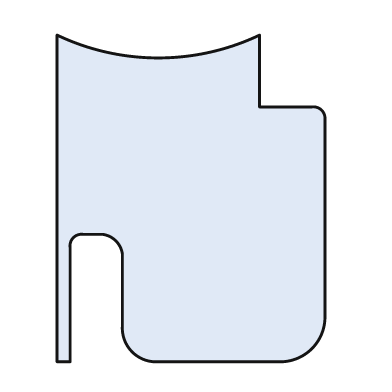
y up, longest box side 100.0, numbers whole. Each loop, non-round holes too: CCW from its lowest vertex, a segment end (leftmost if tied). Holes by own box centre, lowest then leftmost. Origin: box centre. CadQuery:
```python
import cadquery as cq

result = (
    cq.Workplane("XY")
    .moveTo(-41.0, -50.0)
    .lineTo(-37.0, -50.0)
    .lineTo(-37.0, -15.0)
    .threePointArc((-36.0, -12.0), (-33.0, -11.0))
    .lineTo(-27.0, -11.0)
    .threePointArc((-23.0, -13.0), (-21.0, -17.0))
    .lineTo(-21.0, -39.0)
    .threePointArc((-18.0, -47.0), (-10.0, -50.0))
    .lineTo(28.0, -50.0)
    .threePointArc((37.0, -46.0), (41.0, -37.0))
    .lineTo(41.0, 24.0)
    .threePointArc((40.0, 27.0), (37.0, 28.0))
    .lineTo(21.0, 28.0)
    .lineTo(21.0, 50.0)
    .threePointArc((-10.0, 43.0), (-41.0, 50.0))
    .close()
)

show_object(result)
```